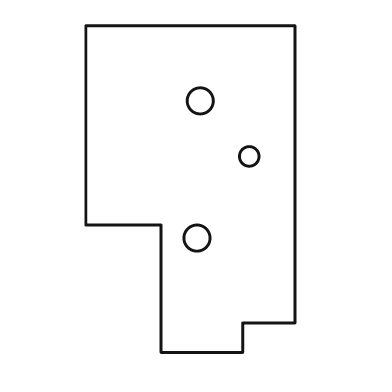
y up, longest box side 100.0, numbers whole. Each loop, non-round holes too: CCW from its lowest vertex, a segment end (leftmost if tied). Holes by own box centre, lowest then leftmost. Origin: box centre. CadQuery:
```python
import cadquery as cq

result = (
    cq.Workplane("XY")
    .moveTo(-9.0, -50.0)
    .lineTo(16.0, -50.0)
    .lineTo(16.0, -41.0)
    .lineTo(32.0, -41.0)
    .lineTo(32.0, 50.0)
    .lineTo(-32.0, 50.0)
    .lineTo(-32.0, -11.0)
    .lineTo(-9.0, -11.0)
    .close()
    .moveTo(2.0, -15.0)
    .circle(4.0)
    .moveTo(18.0, 10.0)
    .circle(3.0)
    .moveTo(3.0, 27.0)
    .circle(4.0)
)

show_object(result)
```